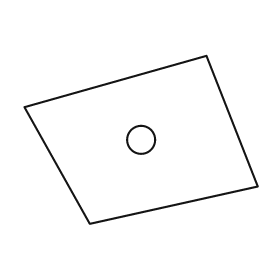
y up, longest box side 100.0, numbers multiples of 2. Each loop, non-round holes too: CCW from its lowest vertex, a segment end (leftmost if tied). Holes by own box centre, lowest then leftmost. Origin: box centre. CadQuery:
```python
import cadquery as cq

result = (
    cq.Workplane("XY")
    .moveTo(-22.0, -36.0)
    .lineTo(50.0, -20.0)
    .lineTo(28.0, 36.0)
    .lineTo(-50.0, 14.0)
    .close()
    .moveTo(0.0, 0.0)
    .circle(6.0)
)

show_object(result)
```